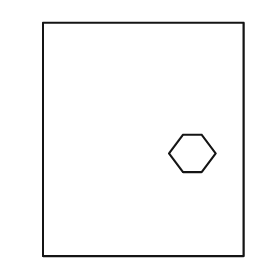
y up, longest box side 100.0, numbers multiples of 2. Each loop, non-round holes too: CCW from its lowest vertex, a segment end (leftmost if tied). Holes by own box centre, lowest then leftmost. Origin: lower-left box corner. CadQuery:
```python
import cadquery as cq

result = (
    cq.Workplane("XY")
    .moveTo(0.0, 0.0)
    .lineTo(86.0, 0.0)
    .lineTo(86.0, 100.0)
    .lineTo(0.0, 100.0)
    .close()
    .moveTo(60.0, 36.0)
    .lineTo(68.0, 36.0)
    .lineTo(74.0, 44.0)
    .lineTo(68.0, 52.0)
    .lineTo(60.0, 52.0)
    .lineTo(54.0, 44.0)
    .close()
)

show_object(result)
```